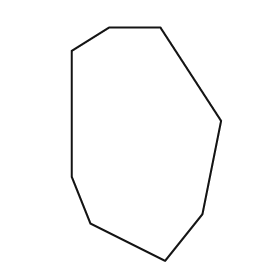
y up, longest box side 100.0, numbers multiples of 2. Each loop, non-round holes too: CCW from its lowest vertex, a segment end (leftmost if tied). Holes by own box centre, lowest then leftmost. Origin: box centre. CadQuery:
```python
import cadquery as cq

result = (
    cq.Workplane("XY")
    .moveTo(8.0, -50.0)
    .lineTo(24.0, -30.0)
    .lineTo(32.0, 10.0)
    .lineTo(6.0, 50.0)
    .lineTo(-16.0, 50.0)
    .lineTo(-32.0, 40.0)
    .lineTo(-32.0, -14.0)
    .lineTo(-24.0, -34.0)
    .close()
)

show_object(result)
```